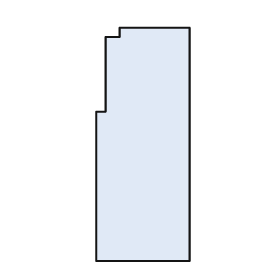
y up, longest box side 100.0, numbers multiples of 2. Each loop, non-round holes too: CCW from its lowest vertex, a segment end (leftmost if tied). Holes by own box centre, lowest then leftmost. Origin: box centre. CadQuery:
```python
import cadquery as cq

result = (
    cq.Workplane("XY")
    .moveTo(-20.0, -50.0)
    .lineTo(20.0, -50.0)
    .lineTo(20.0, 50.0)
    .lineTo(-10.0, 50.0)
    .lineTo(-10.0, 46.0)
    .lineTo(-16.0, 46.0)
    .lineTo(-16.0, 14.0)
    .lineTo(-20.0, 14.0)
    .close()
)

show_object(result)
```